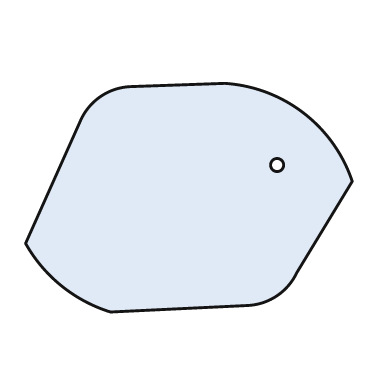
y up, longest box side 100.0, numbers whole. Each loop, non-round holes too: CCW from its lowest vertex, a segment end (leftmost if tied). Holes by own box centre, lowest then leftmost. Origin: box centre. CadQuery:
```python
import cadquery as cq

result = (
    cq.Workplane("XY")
    .moveTo(-24.0, -35.0)
    .lineTo(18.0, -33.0)
    .threePointArc((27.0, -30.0), (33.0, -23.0))
    .lineTo(50.0, 5.0)
    .threePointArc((35.0, 26.0), (11.0, 35.0))
    .lineTo(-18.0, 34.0)
    .threePointArc((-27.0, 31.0), (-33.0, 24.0))
    .lineTo(-50.0, -14.0)
    .threePointArc((-39.0, -27.0), (-24.0, -35.0))
    .close()
    .moveTo(27.0, 10.0)
    .circle(2.0)
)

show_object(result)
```